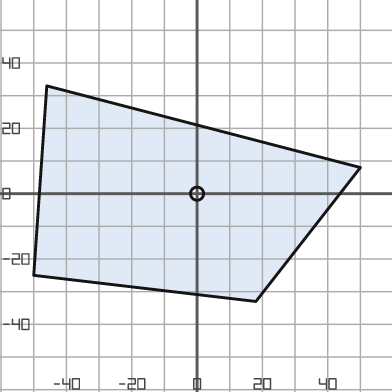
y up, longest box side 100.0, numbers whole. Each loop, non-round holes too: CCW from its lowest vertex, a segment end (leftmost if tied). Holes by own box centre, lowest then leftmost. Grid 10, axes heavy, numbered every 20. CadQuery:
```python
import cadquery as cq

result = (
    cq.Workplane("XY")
    .moveTo(18.0, -33.0)
    .lineTo(50.0, 8.0)
    .lineTo(-46.0, 33.0)
    .lineTo(-50.0, -25.0)
    .close()
    .moveTo(0.0, 0.0)
    .circle(2.0)
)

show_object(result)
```